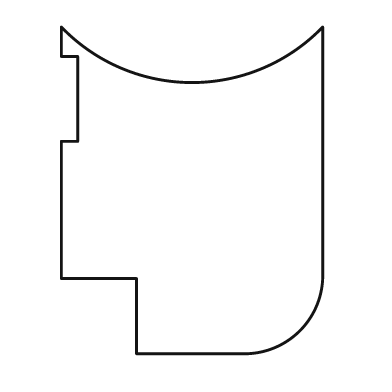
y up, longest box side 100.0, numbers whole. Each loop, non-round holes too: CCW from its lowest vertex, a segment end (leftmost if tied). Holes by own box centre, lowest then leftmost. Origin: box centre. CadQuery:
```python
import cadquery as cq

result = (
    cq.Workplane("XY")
    .moveTo(-17.0, -50.0)
    .lineTo(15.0, -50.0)
    .threePointArc((33.0, -43.0), (40.0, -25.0))
    .lineTo(40.0, 50.0)
    .threePointArc((0.0, 33.0), (-40.0, 50.0))
    .lineTo(-40.0, 41.0)
    .lineTo(-35.0, 41.0)
    .lineTo(-35.0, 15.0)
    .lineTo(-40.0, 15.0)
    .lineTo(-40.0, -27.0)
    .lineTo(-17.0, -27.0)
    .close()
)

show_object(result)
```